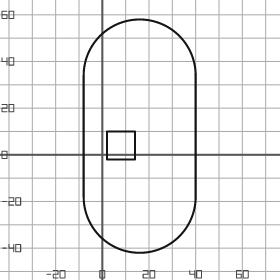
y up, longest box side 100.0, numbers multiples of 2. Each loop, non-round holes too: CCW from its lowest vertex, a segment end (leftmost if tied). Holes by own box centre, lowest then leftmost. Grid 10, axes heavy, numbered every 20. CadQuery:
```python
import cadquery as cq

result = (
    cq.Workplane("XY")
    .moveTo(-8.0, -18.0)
    .threePointArc((16.0, -42.0), (40.0, -18.0))
    .lineTo(40.0, 34.0)
    .threePointArc((16.0, 58.0), (-8.0, 34.0))
    .close()
    .moveTo(2.0, -2.0)
    .lineTo(14.0, -2.0)
    .lineTo(14.0, 10.0)
    .lineTo(2.0, 10.0)
    .close()
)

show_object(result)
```